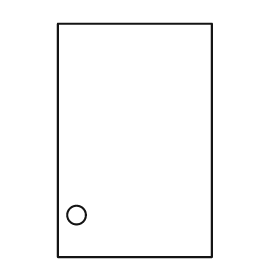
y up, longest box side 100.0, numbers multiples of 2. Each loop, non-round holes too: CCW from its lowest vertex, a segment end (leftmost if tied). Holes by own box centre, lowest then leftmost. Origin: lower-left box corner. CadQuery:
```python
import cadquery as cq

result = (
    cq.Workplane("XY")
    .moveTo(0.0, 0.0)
    .lineTo(66.0, 0.0)
    .lineTo(66.0, 100.0)
    .lineTo(0.0, 100.0)
    .close()
    .moveTo(8.0, 18.0)
    .circle(4.0)
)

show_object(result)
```